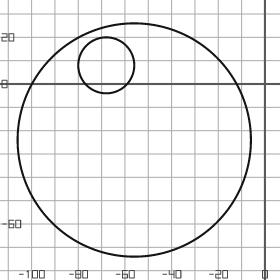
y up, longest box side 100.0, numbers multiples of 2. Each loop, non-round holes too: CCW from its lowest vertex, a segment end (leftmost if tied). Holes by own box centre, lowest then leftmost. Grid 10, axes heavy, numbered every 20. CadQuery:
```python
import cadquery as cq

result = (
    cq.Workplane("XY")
    .moveTo(-56.0, -24.0)
    .circle(50.0)
    .moveTo(-68.0, 8.0)
    .circle(12.0)
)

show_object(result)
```